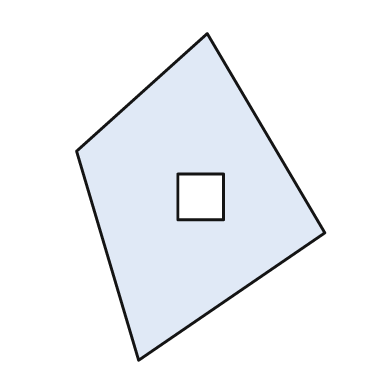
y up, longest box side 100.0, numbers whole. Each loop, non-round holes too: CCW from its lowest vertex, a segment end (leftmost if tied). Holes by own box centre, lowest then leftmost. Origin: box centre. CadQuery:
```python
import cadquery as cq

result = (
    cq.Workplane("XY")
    .moveTo(-19.0, -50.0)
    .lineTo(38.0, -11.0)
    .lineTo(2.0, 50.0)
    .lineTo(-38.0, 14.0)
    .close()
    .moveTo(-7.0, -7.0)
    .lineTo(7.0, -7.0)
    .lineTo(7.0, 7.0)
    .lineTo(-7.0, 7.0)
    .close()
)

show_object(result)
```